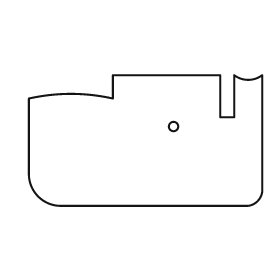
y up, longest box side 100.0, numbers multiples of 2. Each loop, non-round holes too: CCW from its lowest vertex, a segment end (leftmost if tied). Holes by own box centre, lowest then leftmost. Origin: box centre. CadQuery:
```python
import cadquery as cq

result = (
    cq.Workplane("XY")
    .moveTo(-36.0, -28.0)
    .lineTo(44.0, -28.0)
    .threePointArc((48.0, -26.0), (50.0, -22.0))
    .lineTo(50.0, 28.0)
    .threePointArc((44.0, 26.0), (38.0, 28.0))
    .lineTo(38.0, 10.0)
    .lineTo(32.0, 10.0)
    .lineTo(32.0, 28.0)
    .lineTo(-14.0, 28.0)
    .lineTo(-14.0, 18.0)
    .threePointArc((-32.0, 20.0), (-50.0, 18.0))
    .lineTo(-50.0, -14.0)
    .threePointArc((-46.0, -24.0), (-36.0, -28.0))
    .close()
    .moveTo(12.0, 6.0)
    .circle(2.0)
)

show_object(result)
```